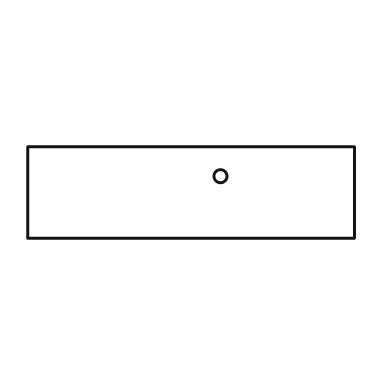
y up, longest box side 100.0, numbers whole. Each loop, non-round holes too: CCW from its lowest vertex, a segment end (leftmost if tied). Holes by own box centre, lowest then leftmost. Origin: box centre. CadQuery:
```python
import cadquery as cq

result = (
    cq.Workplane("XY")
    .moveTo(-50.0, -14.0)
    .lineTo(50.0, -14.0)
    .lineTo(50.0, 14.0)
    .lineTo(-50.0, 14.0)
    .close()
    .moveTo(9.0, 5.0)
    .circle(2.0)
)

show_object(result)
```